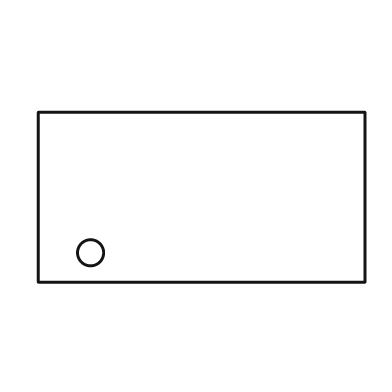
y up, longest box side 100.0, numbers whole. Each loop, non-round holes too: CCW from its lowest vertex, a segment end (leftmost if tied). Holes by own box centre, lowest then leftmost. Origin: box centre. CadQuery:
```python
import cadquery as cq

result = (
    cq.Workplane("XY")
    .moveTo(-50.0, -26.0)
    .lineTo(50.0, -26.0)
    .lineTo(50.0, 26.0)
    .lineTo(-50.0, 26.0)
    .close()
    .moveTo(-34.0, -17.0)
    .circle(4.0)
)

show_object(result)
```